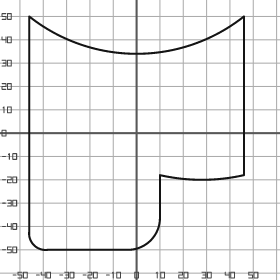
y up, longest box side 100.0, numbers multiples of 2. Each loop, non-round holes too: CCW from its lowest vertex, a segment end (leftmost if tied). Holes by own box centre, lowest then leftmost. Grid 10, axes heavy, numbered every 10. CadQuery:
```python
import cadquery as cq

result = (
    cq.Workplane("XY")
    .moveTo(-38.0, -50.0)
    .lineTo(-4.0, -50.0)
    .threePointArc((6.0, -46.0), (10.0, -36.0))
    .lineTo(10.0, -18.0)
    .threePointArc((28.0, -20.0), (46.0, -18.0))
    .lineTo(46.0, 50.0)
    .threePointArc((0.0, 34.0), (-46.0, 50.0))
    .lineTo(-46.0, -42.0)
    .threePointArc((-44.0, -48.0), (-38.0, -50.0))
    .close()
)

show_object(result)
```